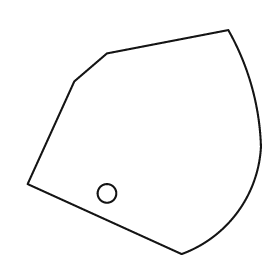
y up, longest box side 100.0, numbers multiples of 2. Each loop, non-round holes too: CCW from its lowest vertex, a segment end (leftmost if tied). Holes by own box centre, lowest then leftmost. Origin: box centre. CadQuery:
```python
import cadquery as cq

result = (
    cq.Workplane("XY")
    .moveTo(16.0, -48.0)
    .threePointArc((40.0, -30.0), (50.0, -2.0))
    .threePointArc((46.0, 24.0), (36.0, 48.0))
    .lineTo(-16.0, 38.0)
    .lineTo(-30.0, 26.0)
    .lineTo(-50.0, -18.0)
    .close()
    .moveTo(-16.0, -22.0)
    .circle(4.0)
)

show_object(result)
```